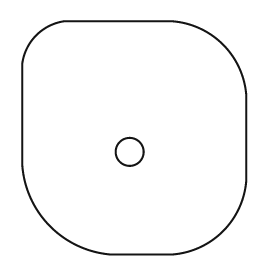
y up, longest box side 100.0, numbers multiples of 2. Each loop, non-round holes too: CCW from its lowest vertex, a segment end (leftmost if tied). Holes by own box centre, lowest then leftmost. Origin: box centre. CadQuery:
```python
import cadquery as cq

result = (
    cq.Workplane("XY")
    .moveTo(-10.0, -50.0)
    .lineTo(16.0, -50.0)
    .threePointArc((38.0, -40.0), (48.0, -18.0))
    .lineTo(48.0, 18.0)
    .threePointArc((38.0, 40.0), (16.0, 50.0))
    .lineTo(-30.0, 50.0)
    .threePointArc((-42.0, 44.0), (-48.0, 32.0))
    .lineTo(-48.0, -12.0)
    .threePointArc((-36.0, -38.0), (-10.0, -50.0))
    .close()
    .moveTo(-2.0, -6.0)
    .circle(6.0)
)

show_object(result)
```